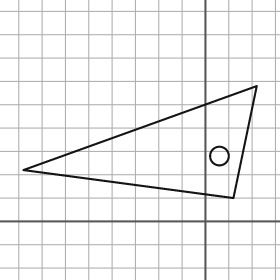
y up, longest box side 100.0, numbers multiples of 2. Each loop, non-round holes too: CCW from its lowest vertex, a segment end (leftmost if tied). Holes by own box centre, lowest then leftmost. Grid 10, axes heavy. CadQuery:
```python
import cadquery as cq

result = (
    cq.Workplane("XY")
    .moveTo(12.0, 10.0)
    .lineTo(22.0, 58.0)
    .lineTo(-78.0, 22.0)
    .close()
    .moveTo(6.0, 28.0)
    .circle(4.0)
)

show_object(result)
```